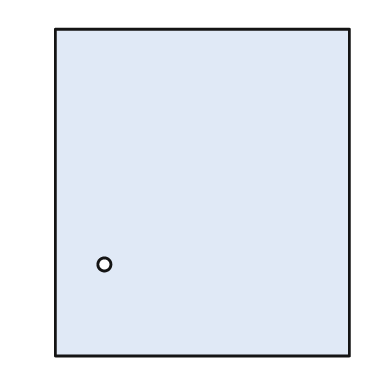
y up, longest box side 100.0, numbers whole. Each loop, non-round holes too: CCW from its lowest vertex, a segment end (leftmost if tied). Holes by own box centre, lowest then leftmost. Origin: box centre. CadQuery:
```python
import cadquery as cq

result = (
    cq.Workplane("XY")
    .moveTo(-45.0, -50.0)
    .lineTo(45.0, -50.0)
    .lineTo(45.0, 50.0)
    .lineTo(-45.0, 50.0)
    .close()
    .moveTo(-30.0, -22.0)
    .circle(2.0)
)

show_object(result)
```